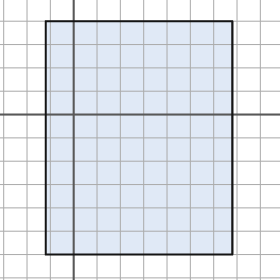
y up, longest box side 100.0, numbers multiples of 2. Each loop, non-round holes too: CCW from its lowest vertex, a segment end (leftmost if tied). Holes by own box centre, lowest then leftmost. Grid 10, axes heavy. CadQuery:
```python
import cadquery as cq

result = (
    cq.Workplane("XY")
    .moveTo(-12.0, -60.0)
    .lineTo(68.0, -60.0)
    .lineTo(68.0, 40.0)
    .lineTo(-12.0, 40.0)
    .close()
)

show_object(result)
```